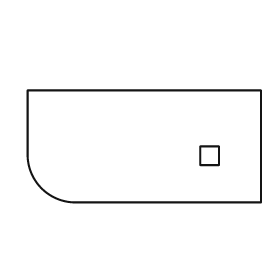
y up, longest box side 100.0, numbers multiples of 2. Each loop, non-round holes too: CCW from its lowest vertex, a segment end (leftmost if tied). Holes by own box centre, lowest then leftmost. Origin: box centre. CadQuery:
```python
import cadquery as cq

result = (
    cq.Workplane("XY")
    .moveTo(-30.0, -24.0)
    .lineTo(50.0, -24.0)
    .lineTo(50.0, 24.0)
    .lineTo(-50.0, 24.0)
    .lineTo(-50.0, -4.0)
    .threePointArc((-44.0, -18.0), (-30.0, -24.0))
    .close()
    .moveTo(24.0, -8.0)
    .lineTo(32.0, -8.0)
    .lineTo(32.0, 0.0)
    .lineTo(24.0, 0.0)
    .close()
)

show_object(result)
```